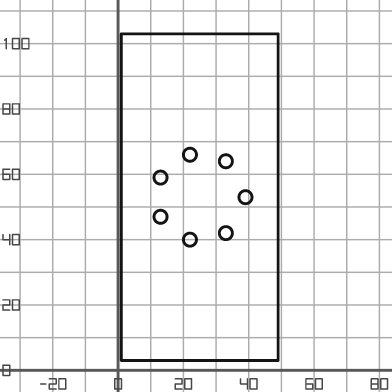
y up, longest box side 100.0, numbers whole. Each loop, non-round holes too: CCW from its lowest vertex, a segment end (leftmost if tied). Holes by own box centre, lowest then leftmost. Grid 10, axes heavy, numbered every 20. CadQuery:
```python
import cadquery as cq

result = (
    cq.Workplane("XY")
    .moveTo(1.0, 3.0)
    .lineTo(49.0, 3.0)
    .lineTo(49.0, 103.0)
    .lineTo(1.0, 103.0)
    .close()
    .moveTo(22.0, 40.0)
    .circle(2.0)
    .moveTo(33.0, 42.0)
    .circle(2.0)
    .moveTo(13.0, 47.0)
    .circle(2.0)
    .moveTo(39.0, 53.0)
    .circle(2.0)
    .moveTo(13.0, 59.0)
    .circle(2.0)
    .moveTo(33.0, 64.0)
    .circle(2.0)
    .moveTo(22.0, 66.0)
    .circle(2.0)
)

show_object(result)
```